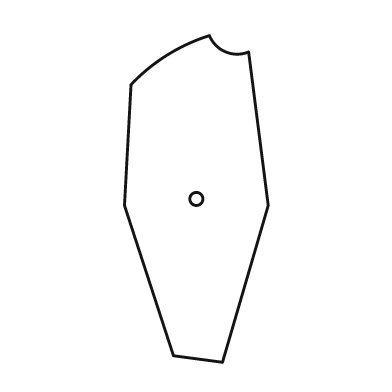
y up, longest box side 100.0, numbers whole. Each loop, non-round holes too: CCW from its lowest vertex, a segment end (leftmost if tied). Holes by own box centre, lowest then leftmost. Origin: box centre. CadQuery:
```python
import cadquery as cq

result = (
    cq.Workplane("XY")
    .moveTo(8.0, -50.0)
    .lineTo(22.0, -2.0)
    .lineTo(16.0, 45.0)
    .threePointArc((9.0, 45.0), (4.0, 50.0))
    .threePointArc((-9.0, 44.0), (-20.0, 35.0))
    .lineTo(-22.0, -2.0)
    .lineTo(-7.0, -48.0)
    .close()
    .moveTo(0.0, 0.0)
    .circle(2.0)
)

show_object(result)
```